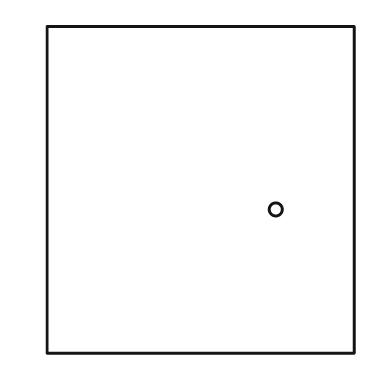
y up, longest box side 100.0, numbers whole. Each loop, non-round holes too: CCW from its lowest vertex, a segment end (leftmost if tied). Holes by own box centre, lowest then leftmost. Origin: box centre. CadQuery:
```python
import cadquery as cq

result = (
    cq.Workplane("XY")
    .moveTo(-47.0, -50.0)
    .lineTo(47.0, -50.0)
    .lineTo(47.0, 50.0)
    .lineTo(-47.0, 50.0)
    .close()
    .moveTo(23.0, -6.0)
    .circle(2.0)
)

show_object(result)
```